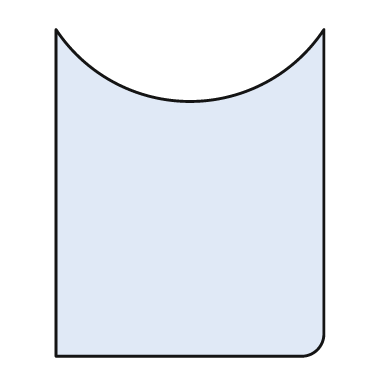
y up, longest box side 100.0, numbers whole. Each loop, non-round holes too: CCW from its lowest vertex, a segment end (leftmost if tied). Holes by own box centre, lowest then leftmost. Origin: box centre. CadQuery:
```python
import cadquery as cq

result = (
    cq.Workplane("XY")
    .moveTo(-41.0, -50.0)
    .lineTo(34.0, -50.0)
    .threePointArc((39.0, -48.0), (41.0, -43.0))
    .lineTo(41.0, 50.0)
    .threePointArc((0.0, 28.0), (-41.0, 50.0))
    .close()
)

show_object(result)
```